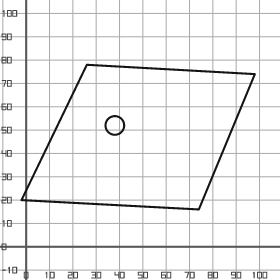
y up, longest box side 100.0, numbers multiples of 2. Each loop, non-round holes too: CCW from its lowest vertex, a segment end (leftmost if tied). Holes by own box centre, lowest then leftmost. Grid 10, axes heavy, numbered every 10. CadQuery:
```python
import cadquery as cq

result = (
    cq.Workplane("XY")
    .moveTo(74.0, 16.0)
    .lineTo(98.0, 74.0)
    .lineTo(26.0, 78.0)
    .lineTo(-2.0, 20.0)
    .close()
    .moveTo(38.0, 52.0)
    .circle(4.0)
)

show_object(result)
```